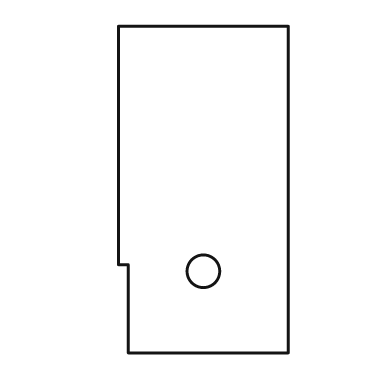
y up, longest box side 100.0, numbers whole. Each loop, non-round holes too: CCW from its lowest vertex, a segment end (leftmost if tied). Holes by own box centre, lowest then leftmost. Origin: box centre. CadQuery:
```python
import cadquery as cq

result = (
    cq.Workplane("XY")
    .moveTo(-23.0, -50.0)
    .lineTo(26.0, -50.0)
    .lineTo(26.0, 50.0)
    .lineTo(-26.0, 50.0)
    .lineTo(-26.0, -23.0)
    .lineTo(-23.0, -23.0)
    .close()
    .moveTo(0.0, -25.0)
    .circle(5.0)
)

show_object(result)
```